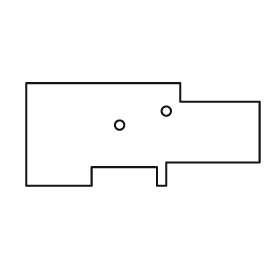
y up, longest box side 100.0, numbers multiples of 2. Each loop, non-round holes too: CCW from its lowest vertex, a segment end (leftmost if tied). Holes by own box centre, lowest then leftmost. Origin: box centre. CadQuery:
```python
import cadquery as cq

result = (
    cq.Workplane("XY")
    .moveTo(-50.0, -22.0)
    .lineTo(-22.0, -22.0)
    .lineTo(-22.0, -14.0)
    .lineTo(6.0, -14.0)
    .lineTo(6.0, -22.0)
    .lineTo(10.0, -22.0)
    .lineTo(10.0, -12.0)
    .lineTo(50.0, -12.0)
    .lineTo(50.0, 14.0)
    .lineTo(16.0, 14.0)
    .lineTo(16.0, 22.0)
    .lineTo(-50.0, 22.0)
    .close()
    .moveTo(-10.0, 4.0)
    .circle(2.0)
    .moveTo(10.0, 10.0)
    .circle(2.0)
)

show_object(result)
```